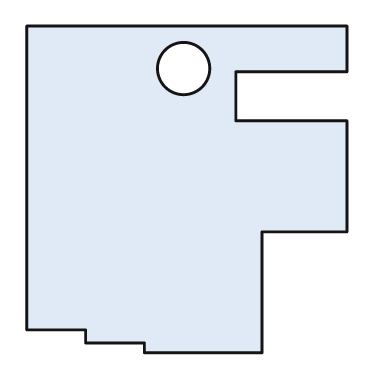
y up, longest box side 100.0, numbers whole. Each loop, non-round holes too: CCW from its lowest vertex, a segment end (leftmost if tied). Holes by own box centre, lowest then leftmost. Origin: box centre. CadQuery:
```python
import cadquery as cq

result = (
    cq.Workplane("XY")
    .moveTo(-13.0, -50.0)
    .lineTo(23.0, -50.0)
    .lineTo(23.0, -13.0)
    .lineTo(49.0, -13.0)
    .lineTo(49.0, 21.0)
    .lineTo(15.0, 21.0)
    .lineTo(15.0, 36.0)
    .lineTo(49.0, 36.0)
    .lineTo(49.0, 50.0)
    .lineTo(-49.0, 50.0)
    .lineTo(-49.0, -43.0)
    .lineTo(-31.0, -43.0)
    .lineTo(-31.0, -47.0)
    .lineTo(-13.0, -47.0)
    .close()
    .moveTo(-1.0, 37.0)
    .circle(8.0)
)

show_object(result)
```